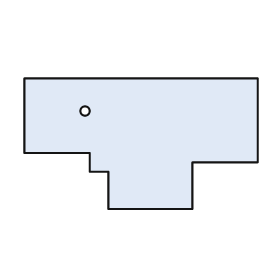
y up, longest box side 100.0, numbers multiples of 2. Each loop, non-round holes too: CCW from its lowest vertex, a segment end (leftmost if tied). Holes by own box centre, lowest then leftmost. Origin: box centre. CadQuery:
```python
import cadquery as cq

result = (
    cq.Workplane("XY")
    .moveTo(-14.0, -28.0)
    .lineTo(22.0, -28.0)
    .lineTo(22.0, -8.0)
    .lineTo(50.0, -8.0)
    .lineTo(50.0, 28.0)
    .lineTo(-50.0, 28.0)
    .lineTo(-50.0, -4.0)
    .lineTo(-22.0, -4.0)
    .lineTo(-22.0, -12.0)
    .lineTo(-14.0, -12.0)
    .close()
    .moveTo(-24.0, 14.0)
    .circle(2.0)
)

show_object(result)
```